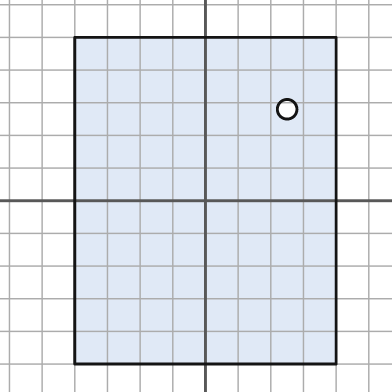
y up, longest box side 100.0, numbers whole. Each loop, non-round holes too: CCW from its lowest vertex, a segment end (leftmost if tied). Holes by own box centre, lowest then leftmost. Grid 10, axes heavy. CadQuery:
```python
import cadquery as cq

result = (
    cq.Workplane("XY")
    .moveTo(-40.0, -50.0)
    .lineTo(40.0, -50.0)
    .lineTo(40.0, 50.0)
    .lineTo(-40.0, 50.0)
    .close()
    .moveTo(25.0, 28.0)
    .circle(3.0)
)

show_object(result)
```